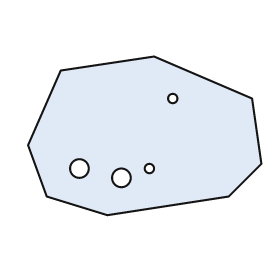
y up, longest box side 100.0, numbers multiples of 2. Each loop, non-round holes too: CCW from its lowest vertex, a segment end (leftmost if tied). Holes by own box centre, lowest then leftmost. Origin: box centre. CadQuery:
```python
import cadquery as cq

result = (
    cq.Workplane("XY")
    .moveTo(-16.0, -34.0)
    .lineTo(36.0, -26.0)
    .lineTo(50.0, -12.0)
    .lineTo(46.0, 16.0)
    .lineTo(4.0, 34.0)
    .lineTo(-36.0, 28.0)
    .lineTo(-50.0, -4.0)
    .lineTo(-42.0, -26.0)
    .close()
    .moveTo(-10.0, -18.0)
    .circle(4.0)
    .moveTo(-28.0, -14.0)
    .circle(4.0)
    .moveTo(2.0, -14.0)
    .circle(2.0)
    .moveTo(12.0, 16.0)
    .circle(2.0)
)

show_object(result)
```